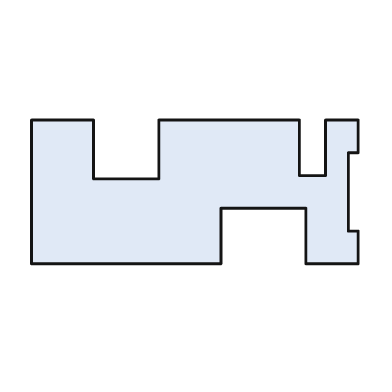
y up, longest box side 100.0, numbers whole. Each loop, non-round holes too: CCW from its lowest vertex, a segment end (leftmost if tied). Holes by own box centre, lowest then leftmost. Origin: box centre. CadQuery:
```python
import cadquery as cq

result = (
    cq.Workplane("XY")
    .moveTo(-50.0, -22.0)
    .lineTo(8.0, -22.0)
    .lineTo(8.0, -5.0)
    .lineTo(34.0, -5.0)
    .lineTo(34.0, -22.0)
    .lineTo(50.0, -22.0)
    .lineTo(50.0, -12.0)
    .lineTo(47.0, -12.0)
    .lineTo(47.0, 12.0)
    .lineTo(50.0, 12.0)
    .lineTo(50.0, 22.0)
    .lineTo(40.0, 22.0)
    .lineTo(40.0, 5.0)
    .lineTo(32.0, 5.0)
    .lineTo(32.0, 22.0)
    .lineTo(-11.0, 22.0)
    .lineTo(-11.0, 4.0)
    .lineTo(-31.0, 4.0)
    .lineTo(-31.0, 22.0)
    .lineTo(-50.0, 22.0)
    .close()
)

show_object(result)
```